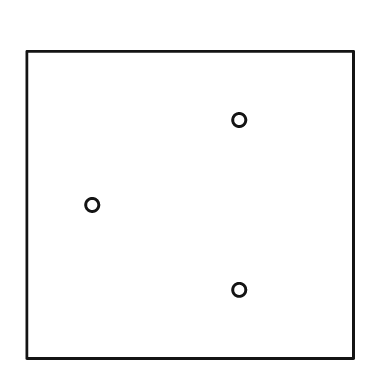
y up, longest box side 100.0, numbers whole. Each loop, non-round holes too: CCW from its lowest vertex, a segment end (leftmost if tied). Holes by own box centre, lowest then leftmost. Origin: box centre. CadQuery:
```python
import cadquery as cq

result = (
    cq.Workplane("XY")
    .moveTo(-50.0, -47.0)
    .lineTo(50.0, -47.0)
    .lineTo(50.0, 47.0)
    .lineTo(-50.0, 47.0)
    .close()
    .moveTo(15.0, -26.0)
    .circle(2.0)
    .moveTo(-30.0, 0.0)
    .circle(2.0)
    .moveTo(15.0, 26.0)
    .circle(2.0)
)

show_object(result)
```